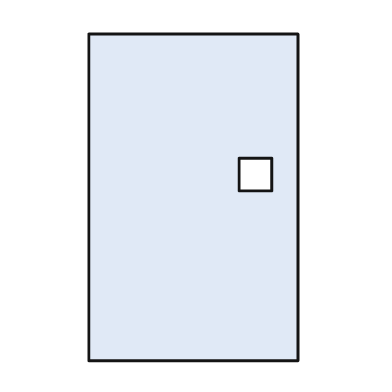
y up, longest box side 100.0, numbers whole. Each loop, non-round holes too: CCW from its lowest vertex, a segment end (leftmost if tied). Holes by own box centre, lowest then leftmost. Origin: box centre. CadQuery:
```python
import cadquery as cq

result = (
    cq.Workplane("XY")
    .moveTo(-32.0, -50.0)
    .lineTo(32.0, -50.0)
    .lineTo(32.0, 50.0)
    .lineTo(-32.0, 50.0)
    .close()
    .moveTo(14.0, 2.0)
    .lineTo(24.0, 2.0)
    .lineTo(24.0, 12.0)
    .lineTo(14.0, 12.0)
    .close()
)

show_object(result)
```